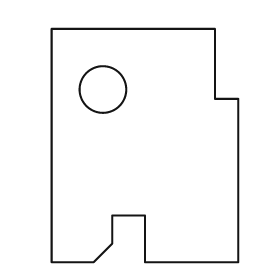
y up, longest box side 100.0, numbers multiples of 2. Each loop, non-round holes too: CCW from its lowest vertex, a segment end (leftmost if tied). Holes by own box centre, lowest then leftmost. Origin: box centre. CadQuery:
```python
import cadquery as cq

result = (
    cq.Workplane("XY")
    .moveTo(-40.0, -50.0)
    .lineTo(-22.0, -50.0)
    .lineTo(-14.0, -42.0)
    .lineTo(-14.0, -30.0)
    .lineTo(0.0, -30.0)
    .lineTo(0.0, -50.0)
    .lineTo(40.0, -50.0)
    .lineTo(40.0, 20.0)
    .lineTo(30.0, 20.0)
    .lineTo(30.0, 50.0)
    .lineTo(-40.0, 50.0)
    .close()
    .moveTo(-18.0, 24.0)
    .circle(10.0)
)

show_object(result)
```